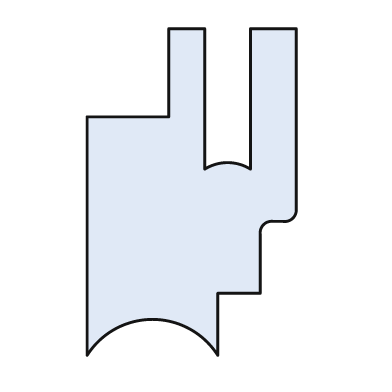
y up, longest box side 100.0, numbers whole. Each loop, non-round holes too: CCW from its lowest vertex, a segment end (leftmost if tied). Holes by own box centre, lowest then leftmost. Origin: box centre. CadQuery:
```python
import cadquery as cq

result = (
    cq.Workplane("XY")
    .moveTo(-32.0, -50.0)
    .threePointArc((-12.0, -39.0), (8.0, -50.0))
    .lineTo(8.0, -31.0)
    .lineTo(21.0, -31.0)
    .lineTo(21.0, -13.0)
    .threePointArc((22.0, -10.0), (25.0, -9.0))
    .lineTo(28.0, -9.0)
    .threePointArc((31.0, -8.0), (32.0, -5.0))
    .lineTo(32.0, 50.0)
    .lineTo(18.0, 50.0)
    .lineTo(18.0, 7.0)
    .threePointArc((11.0, 9.0), (4.0, 7.0))
    .lineTo(4.0, 50.0)
    .lineTo(-7.0, 50.0)
    .lineTo(-7.0, 23.0)
    .lineTo(-32.0, 23.0)
    .close()
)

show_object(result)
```